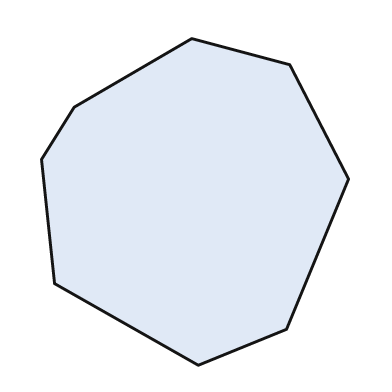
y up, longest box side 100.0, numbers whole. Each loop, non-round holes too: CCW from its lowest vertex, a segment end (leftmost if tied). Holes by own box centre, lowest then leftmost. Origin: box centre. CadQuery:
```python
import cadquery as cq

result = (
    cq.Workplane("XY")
    .moveTo(1.0, -50.0)
    .lineTo(28.0, -39.0)
    .lineTo(47.0, 7.0)
    .lineTo(29.0, 42.0)
    .lineTo(-1.0, 50.0)
    .lineTo(-37.0, 29.0)
    .lineTo(-47.0, 13.0)
    .lineTo(-43.0, -25.0)
    .close()
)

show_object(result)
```